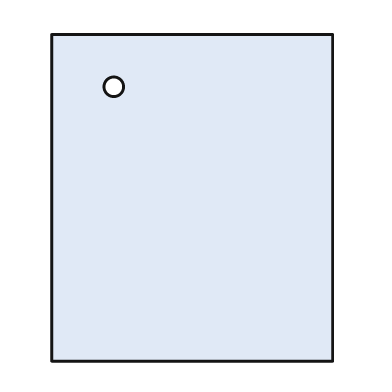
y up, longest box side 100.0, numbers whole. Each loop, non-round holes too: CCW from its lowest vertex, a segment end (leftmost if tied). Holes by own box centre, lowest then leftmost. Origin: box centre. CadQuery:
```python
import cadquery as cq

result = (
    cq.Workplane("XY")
    .moveTo(-43.0, -50.0)
    .lineTo(43.0, -50.0)
    .lineTo(43.0, 50.0)
    .lineTo(-43.0, 50.0)
    .close()
    .moveTo(-24.0, 34.0)
    .circle(3.0)
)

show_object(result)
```